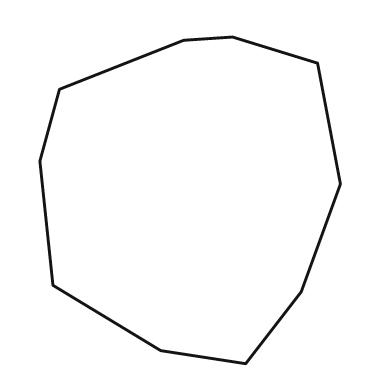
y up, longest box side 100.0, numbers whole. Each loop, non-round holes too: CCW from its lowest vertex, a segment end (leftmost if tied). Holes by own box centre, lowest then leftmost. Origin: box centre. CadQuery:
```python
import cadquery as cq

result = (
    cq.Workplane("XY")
    .moveTo(17.0, -50.0)
    .lineTo(34.0, -28.0)
    .lineTo(46.0, 5.0)
    .lineTo(39.0, 42.0)
    .lineTo(13.0, 50.0)
    .lineTo(-2.0, 49.0)
    .lineTo(-40.0, 34.0)
    .lineTo(-46.0, 12.0)
    .lineTo(-42.0, -26.0)
    .lineTo(-9.0, -46.0)
    .close()
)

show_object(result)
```